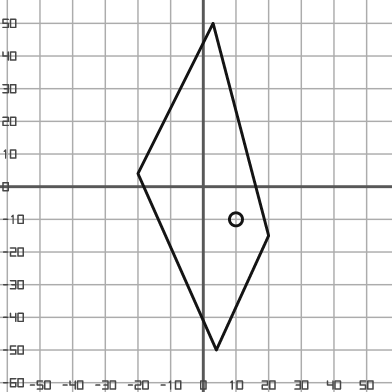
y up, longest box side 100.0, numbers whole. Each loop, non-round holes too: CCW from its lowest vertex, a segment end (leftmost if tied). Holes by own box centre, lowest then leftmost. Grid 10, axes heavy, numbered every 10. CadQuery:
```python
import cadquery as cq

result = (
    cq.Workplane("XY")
    .moveTo(4.0, -50.0)
    .lineTo(20.0, -15.0)
    .lineTo(3.0, 50.0)
    .lineTo(-20.0, 4.0)
    .close()
    .moveTo(10.0, -10.0)
    .circle(2.0)
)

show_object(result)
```